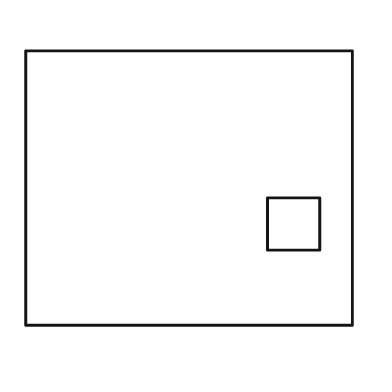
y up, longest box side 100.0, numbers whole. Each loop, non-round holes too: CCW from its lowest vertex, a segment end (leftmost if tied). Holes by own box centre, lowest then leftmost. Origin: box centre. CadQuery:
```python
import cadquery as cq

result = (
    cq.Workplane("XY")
    .moveTo(-50.0, -42.0)
    .lineTo(50.0, -42.0)
    .lineTo(50.0, 42.0)
    .lineTo(-50.0, 42.0)
    .close()
    .moveTo(24.0, -19.0)
    .lineTo(40.0, -19.0)
    .lineTo(40.0, -3.0)
    .lineTo(24.0, -3.0)
    .close()
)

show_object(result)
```